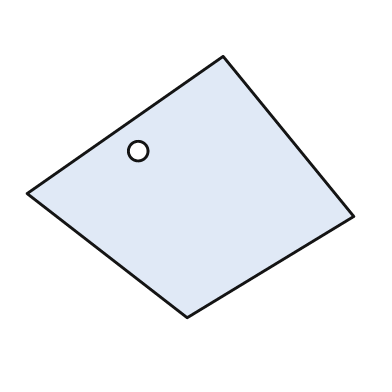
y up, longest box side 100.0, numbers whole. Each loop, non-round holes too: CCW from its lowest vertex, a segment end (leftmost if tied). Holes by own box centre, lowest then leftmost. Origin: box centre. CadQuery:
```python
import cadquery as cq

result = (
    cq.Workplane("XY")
    .moveTo(-1.0, -40.0)
    .lineTo(50.0, -9.0)
    .lineTo(10.0, 40.0)
    .lineTo(-50.0, -2.0)
    .close()
    .moveTo(-16.0, 11.0)
    .circle(3.0)
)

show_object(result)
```